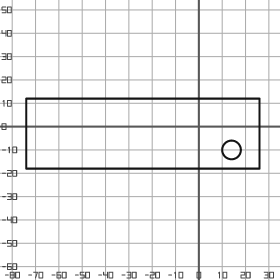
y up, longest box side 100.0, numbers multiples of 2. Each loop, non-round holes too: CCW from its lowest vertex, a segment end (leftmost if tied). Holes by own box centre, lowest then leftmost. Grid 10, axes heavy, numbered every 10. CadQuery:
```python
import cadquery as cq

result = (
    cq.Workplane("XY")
    .moveTo(-74.0, -18.0)
    .lineTo(26.0, -18.0)
    .lineTo(26.0, 12.0)
    .lineTo(-74.0, 12.0)
    .close()
    .moveTo(14.0, -10.0)
    .circle(4.0)
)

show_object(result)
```